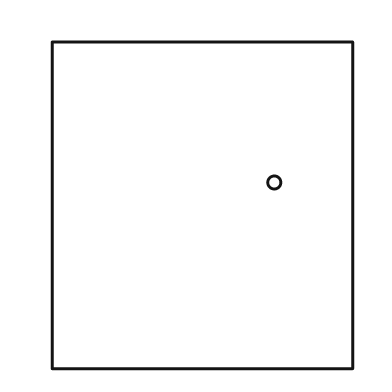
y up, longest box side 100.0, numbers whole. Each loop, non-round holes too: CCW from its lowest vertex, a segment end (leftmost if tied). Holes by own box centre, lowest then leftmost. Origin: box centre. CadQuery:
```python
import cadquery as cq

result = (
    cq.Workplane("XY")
    .moveTo(-46.0, -50.0)
    .lineTo(46.0, -50.0)
    .lineTo(46.0, 50.0)
    .lineTo(-46.0, 50.0)
    .close()
    .moveTo(22.0, 7.0)
    .circle(2.0)
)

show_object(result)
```